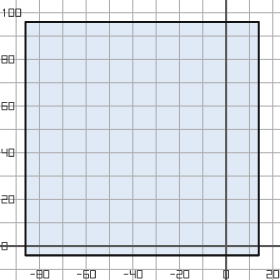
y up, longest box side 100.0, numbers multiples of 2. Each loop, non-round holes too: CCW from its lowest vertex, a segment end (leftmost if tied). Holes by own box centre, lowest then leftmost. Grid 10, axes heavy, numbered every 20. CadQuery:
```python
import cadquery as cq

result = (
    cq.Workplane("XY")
    .moveTo(-86.0, -4.0)
    .lineTo(14.0, -4.0)
    .lineTo(14.0, 96.0)
    .lineTo(-86.0, 96.0)
    .close()
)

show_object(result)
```